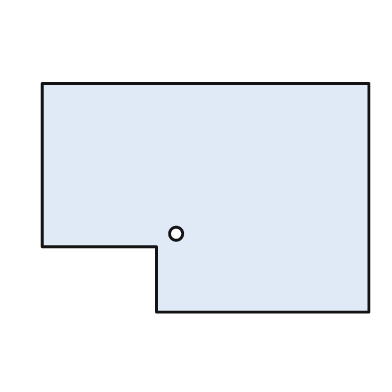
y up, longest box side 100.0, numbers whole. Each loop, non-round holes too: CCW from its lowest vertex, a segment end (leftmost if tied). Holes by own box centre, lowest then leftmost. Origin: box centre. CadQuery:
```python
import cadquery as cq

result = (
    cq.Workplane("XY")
    .moveTo(-15.0, -35.0)
    .lineTo(50.0, -35.0)
    .lineTo(50.0, 35.0)
    .lineTo(-50.0, 35.0)
    .lineTo(-50.0, -15.0)
    .lineTo(-15.0, -15.0)
    .close()
    .moveTo(-9.0, -11.0)
    .circle(2.0)
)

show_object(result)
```